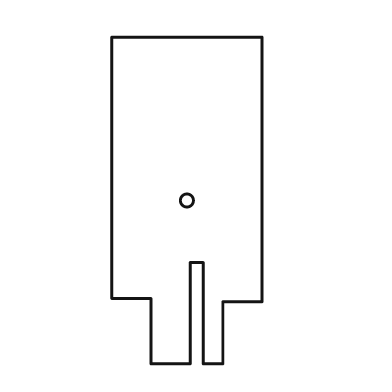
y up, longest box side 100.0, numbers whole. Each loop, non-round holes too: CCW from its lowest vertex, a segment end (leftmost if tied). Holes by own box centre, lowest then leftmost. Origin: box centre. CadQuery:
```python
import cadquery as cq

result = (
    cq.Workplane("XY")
    .moveTo(-11.0, -50.0)
    .lineTo(1.0, -50.0)
    .lineTo(1.0, -19.0)
    .lineTo(5.0, -19.0)
    .lineTo(5.0, -50.0)
    .lineTo(11.0, -50.0)
    .lineTo(11.0, -31.0)
    .lineTo(23.0, -31.0)
    .lineTo(23.0, 50.0)
    .lineTo(-23.0, 50.0)
    .lineTo(-23.0, -30.0)
    .lineTo(-11.0, -30.0)
    .close()
    .moveTo(0.0, 0.0)
    .circle(2.0)
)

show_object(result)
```